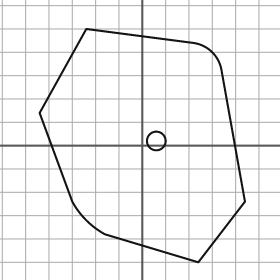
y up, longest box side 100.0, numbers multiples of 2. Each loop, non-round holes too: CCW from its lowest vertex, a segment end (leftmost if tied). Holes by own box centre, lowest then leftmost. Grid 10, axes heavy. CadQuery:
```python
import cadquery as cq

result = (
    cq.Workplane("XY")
    .moveTo(24.0, -50.0)
    .lineTo(44.0, -24.0)
    .lineTo(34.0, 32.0)
    .threePointArc((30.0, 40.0), (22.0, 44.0))
    .lineTo(-24.0, 50.0)
    .lineTo(-44.0, 14.0)
    .lineTo(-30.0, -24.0)
    .threePointArc((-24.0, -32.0), (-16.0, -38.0))
    .close()
    .moveTo(6.0, 2.0)
    .circle(4.0)
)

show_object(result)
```